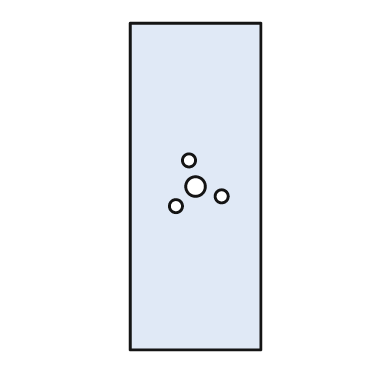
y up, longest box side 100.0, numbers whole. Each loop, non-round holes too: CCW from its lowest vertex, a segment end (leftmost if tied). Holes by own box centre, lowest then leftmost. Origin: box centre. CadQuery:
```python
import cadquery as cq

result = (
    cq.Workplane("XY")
    .moveTo(-20.0, -50.0)
    .lineTo(20.0, -50.0)
    .lineTo(20.0, 50.0)
    .lineTo(-20.0, 50.0)
    .close()
    .moveTo(-6.0, -6.0)
    .circle(2.0)
    .moveTo(8.0, -3.0)
    .circle(2.0)
    .moveTo(0.0, 0.0)
    .circle(3.0)
    .moveTo(-2.0, 8.0)
    .circle(2.0)
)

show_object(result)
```